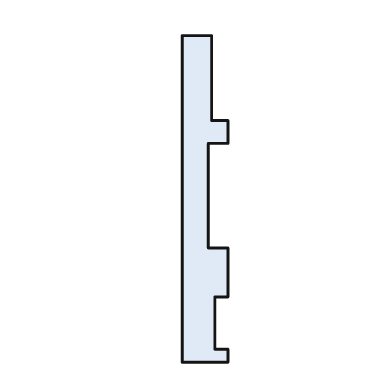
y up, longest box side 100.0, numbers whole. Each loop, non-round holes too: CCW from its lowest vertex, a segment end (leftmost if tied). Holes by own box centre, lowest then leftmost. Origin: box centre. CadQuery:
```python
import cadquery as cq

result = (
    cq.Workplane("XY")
    .moveTo(-7.0, -50.0)
    .lineTo(7.0, -50.0)
    .lineTo(7.0, -46.0)
    .lineTo(3.0, -46.0)
    .lineTo(3.0, -30.0)
    .lineTo(7.0, -30.0)
    .lineTo(7.0, -15.0)
    .lineTo(1.0, -15.0)
    .lineTo(1.0, 17.0)
    .lineTo(7.0, 17.0)
    .lineTo(7.0, 24.0)
    .lineTo(2.0, 24.0)
    .lineTo(2.0, 50.0)
    .lineTo(-7.0, 50.0)
    .close()
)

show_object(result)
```